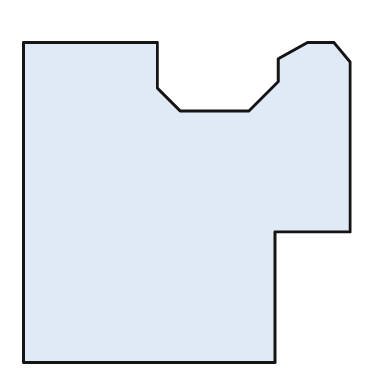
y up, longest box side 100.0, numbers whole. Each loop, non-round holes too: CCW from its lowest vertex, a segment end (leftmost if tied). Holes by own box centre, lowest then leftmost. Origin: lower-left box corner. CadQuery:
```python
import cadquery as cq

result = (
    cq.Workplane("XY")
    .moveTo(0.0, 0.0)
    .lineTo(77.0, 0.0)
    .lineTo(77.0, 40.0)
    .lineTo(100.0, 40.0)
    .lineTo(100.0, 92.0)
    .lineTo(95.0, 98.0)
    .lineTo(87.0, 98.0)
    .lineTo(78.0, 93.0)
    .lineTo(78.0, 86.0)
    .lineTo(69.0, 77.0)
    .lineTo(48.0, 77.0)
    .lineTo(41.0, 84.0)
    .lineTo(41.0, 98.0)
    .lineTo(0.0, 98.0)
    .close()
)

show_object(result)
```